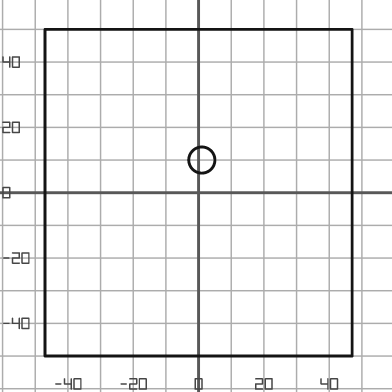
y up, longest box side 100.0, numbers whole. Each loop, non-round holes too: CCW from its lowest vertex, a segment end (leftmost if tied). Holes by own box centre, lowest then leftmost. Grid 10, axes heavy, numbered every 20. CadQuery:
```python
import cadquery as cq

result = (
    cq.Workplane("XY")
    .moveTo(-47.0, -50.0)
    .lineTo(47.0, -50.0)
    .lineTo(47.0, 50.0)
    .lineTo(-47.0, 50.0)
    .close()
    .moveTo(1.0, 10.0)
    .circle(4.0)
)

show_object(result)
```